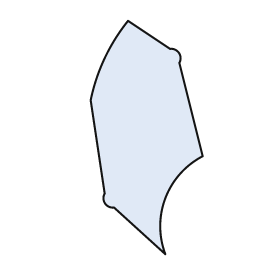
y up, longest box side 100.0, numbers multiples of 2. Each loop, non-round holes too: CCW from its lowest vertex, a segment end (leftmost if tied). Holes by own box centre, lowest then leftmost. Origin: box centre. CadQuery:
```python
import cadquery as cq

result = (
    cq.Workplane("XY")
    .moveTo(8.0, -50.0)
    .threePointArc((8.0, -26.0), (24.0, -8.0))
    .lineTo(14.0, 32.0)
    .threePointArc((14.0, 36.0), (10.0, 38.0))
    .lineTo(-8.0, 50.0)
    .threePointArc((-18.0, 34.0), (-24.0, 16.0))
    .lineTo(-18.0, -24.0)
    .threePointArc((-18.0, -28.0), (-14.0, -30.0))
    .close()
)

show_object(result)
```